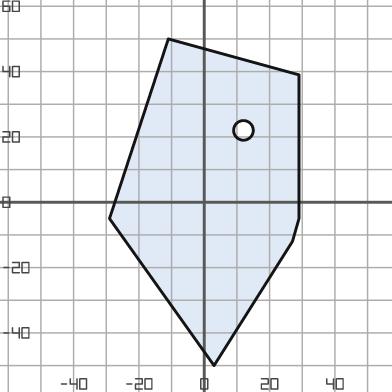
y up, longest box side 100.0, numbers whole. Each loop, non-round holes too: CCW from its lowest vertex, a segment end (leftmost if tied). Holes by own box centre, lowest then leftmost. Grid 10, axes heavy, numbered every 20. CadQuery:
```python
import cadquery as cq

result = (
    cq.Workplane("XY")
    .moveTo(3.0, -50.0)
    .lineTo(27.0, -12.0)
    .lineTo(29.0, -5.0)
    .lineTo(29.0, 39.0)
    .lineTo(-11.0, 50.0)
    .lineTo(-29.0, -5.0)
    .close()
    .moveTo(12.0, 22.0)
    .circle(3.0)
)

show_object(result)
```